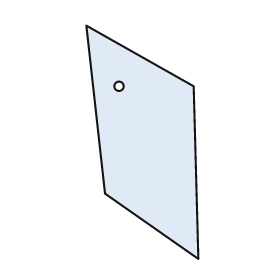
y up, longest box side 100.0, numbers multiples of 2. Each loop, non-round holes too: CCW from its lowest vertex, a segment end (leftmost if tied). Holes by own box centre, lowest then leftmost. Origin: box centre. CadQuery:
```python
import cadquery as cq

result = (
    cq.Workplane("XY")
    .moveTo(24.0, -50.0)
    .lineTo(22.0, 24.0)
    .lineTo(-24.0, 50.0)
    .lineTo(-16.0, -22.0)
    .close()
    .moveTo(-10.0, 24.0)
    .circle(2.0)
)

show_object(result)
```